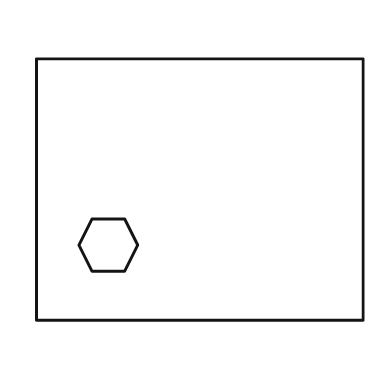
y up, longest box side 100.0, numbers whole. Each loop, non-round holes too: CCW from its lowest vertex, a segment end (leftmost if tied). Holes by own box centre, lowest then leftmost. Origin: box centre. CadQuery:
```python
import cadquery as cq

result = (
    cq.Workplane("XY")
    .moveTo(-50.0, -40.0)
    .lineTo(50.0, -40.0)
    .lineTo(50.0, 40.0)
    .lineTo(-50.0, 40.0)
    .close()
    .moveTo(-33.0, -25.0)
    .lineTo(-23.0, -25.0)
    .lineTo(-19.0, -17.0)
    .lineTo(-23.0, -9.0)
    .lineTo(-33.0, -9.0)
    .lineTo(-37.0, -17.0)
    .close()
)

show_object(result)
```